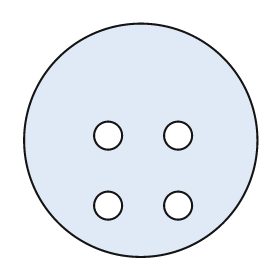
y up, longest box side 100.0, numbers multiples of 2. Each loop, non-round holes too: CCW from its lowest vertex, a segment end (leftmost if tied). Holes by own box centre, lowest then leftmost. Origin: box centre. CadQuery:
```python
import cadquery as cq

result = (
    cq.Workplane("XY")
    .moveTo(0.0, 0.0)
    .circle(50.0)
    .moveTo(-14.0, -28.0)
    .circle(6.0)
    .moveTo(16.0, -28.0)
    .circle(6.0)
    .moveTo(-14.0, 2.0)
    .circle(6.0)
    .moveTo(16.0, 2.0)
    .circle(6.0)
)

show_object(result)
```